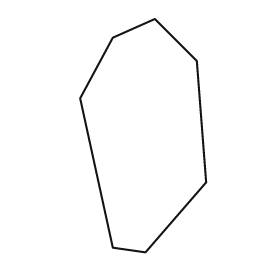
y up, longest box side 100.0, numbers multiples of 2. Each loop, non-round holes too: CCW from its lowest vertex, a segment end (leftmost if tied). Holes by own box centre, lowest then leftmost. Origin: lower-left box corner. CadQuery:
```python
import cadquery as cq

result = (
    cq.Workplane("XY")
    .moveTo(28.0, 0.0)
    .lineTo(54.0, 30.0)
    .lineTo(50.0, 82.0)
    .lineTo(32.0, 100.0)
    .lineTo(14.0, 92.0)
    .lineTo(0.0, 66.0)
    .lineTo(14.0, 2.0)
    .close()
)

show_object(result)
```